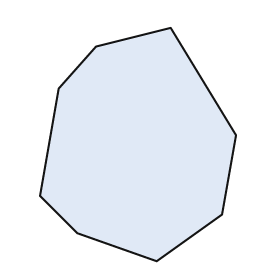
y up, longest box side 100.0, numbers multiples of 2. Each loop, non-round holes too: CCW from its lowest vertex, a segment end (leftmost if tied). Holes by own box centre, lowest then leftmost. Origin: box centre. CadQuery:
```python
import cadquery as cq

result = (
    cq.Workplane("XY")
    .moveTo(8.0, -50.0)
    .lineTo(36.0, -30.0)
    .lineTo(42.0, 4.0)
    .lineTo(14.0, 50.0)
    .lineTo(-18.0, 42.0)
    .lineTo(-34.0, 24.0)
    .lineTo(-42.0, -22.0)
    .lineTo(-26.0, -38.0)
    .close()
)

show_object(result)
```